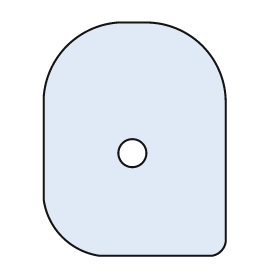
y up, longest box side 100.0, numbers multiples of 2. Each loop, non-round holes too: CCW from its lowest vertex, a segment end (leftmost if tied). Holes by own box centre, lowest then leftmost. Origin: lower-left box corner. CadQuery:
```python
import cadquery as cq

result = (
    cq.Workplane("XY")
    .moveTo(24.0, 0.0)
    .lineTo(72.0, 0.0)
    .threePointArc((76.0, 2.0), (78.0, 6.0))
    .lineTo(78.0, 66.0)
    .threePointArc((68.0, 90.0), (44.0, 100.0))
    .lineTo(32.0, 100.0)
    .threePointArc((10.0, 90.0), (0.0, 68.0))
    .lineTo(0.0, 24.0)
    .threePointArc((8.0, 8.0), (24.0, 0.0))
    .close()
    .moveTo(38.0, 44.0)
    .circle(6.0)
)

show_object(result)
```